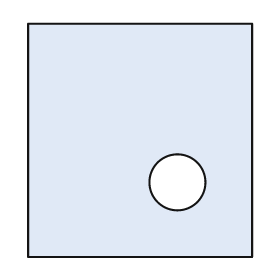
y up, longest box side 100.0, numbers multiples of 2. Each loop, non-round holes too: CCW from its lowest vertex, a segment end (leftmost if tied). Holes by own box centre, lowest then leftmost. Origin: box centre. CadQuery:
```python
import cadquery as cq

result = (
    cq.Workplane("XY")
    .moveTo(-48.0, -50.0)
    .lineTo(48.0, -50.0)
    .lineTo(48.0, 50.0)
    .lineTo(-48.0, 50.0)
    .close()
    .moveTo(16.0, -18.0)
    .circle(12.0)
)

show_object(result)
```